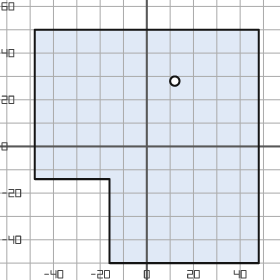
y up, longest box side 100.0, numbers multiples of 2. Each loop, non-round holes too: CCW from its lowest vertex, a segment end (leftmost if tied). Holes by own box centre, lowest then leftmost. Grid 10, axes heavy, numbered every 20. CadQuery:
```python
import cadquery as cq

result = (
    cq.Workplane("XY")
    .moveTo(-16.0, -50.0)
    .lineTo(48.0, -50.0)
    .lineTo(48.0, 50.0)
    .lineTo(-48.0, 50.0)
    .lineTo(-48.0, -14.0)
    .lineTo(-16.0, -14.0)
    .close()
    .moveTo(12.0, 28.0)
    .circle(2.0)
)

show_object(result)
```